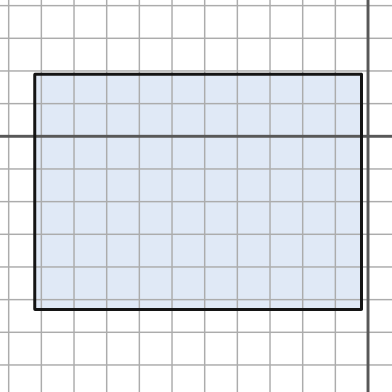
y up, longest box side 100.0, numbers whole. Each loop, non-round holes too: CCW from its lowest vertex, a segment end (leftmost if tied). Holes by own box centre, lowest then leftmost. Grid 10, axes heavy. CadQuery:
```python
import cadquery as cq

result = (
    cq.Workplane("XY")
    .moveTo(-102.0, -53.0)
    .lineTo(-2.0, -53.0)
    .lineTo(-2.0, 19.0)
    .lineTo(-102.0, 19.0)
    .close()
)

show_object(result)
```